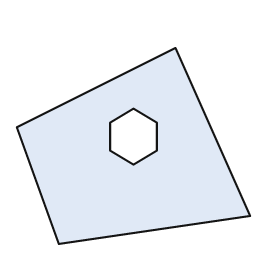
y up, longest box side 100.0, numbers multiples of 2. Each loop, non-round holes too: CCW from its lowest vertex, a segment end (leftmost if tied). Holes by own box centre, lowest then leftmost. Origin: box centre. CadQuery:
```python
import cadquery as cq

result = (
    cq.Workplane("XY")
    .moveTo(-32.0, -42.0)
    .lineTo(50.0, -30.0)
    .lineTo(18.0, 42.0)
    .lineTo(-50.0, 8.0)
    .close()
    .moveTo(0.0, -8.0)
    .lineTo(10.0, -2.0)
    .lineTo(10.0, 10.0)
    .lineTo(0.0, 16.0)
    .lineTo(-10.0, 10.0)
    .lineTo(-10.0, -2.0)
    .close()
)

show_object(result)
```